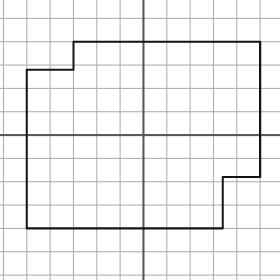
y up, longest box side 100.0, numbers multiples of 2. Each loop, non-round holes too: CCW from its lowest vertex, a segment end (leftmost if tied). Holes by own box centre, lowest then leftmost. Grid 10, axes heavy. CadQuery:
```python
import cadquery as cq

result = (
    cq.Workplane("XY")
    .moveTo(-50.0, -40.0)
    .lineTo(34.0, -40.0)
    .lineTo(34.0, -18.0)
    .lineTo(50.0, -18.0)
    .lineTo(50.0, 40.0)
    .lineTo(-30.0, 40.0)
    .lineTo(-30.0, 28.0)
    .lineTo(-50.0, 28.0)
    .close()
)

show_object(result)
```